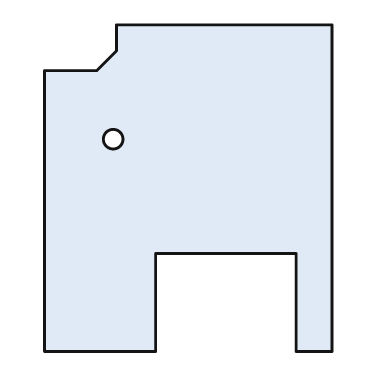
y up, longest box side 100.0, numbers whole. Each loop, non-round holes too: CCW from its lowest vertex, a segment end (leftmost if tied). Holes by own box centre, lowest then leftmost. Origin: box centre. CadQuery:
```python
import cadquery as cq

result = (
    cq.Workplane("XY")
    .moveTo(-44.0, -50.0)
    .lineTo(-10.0, -50.0)
    .lineTo(-10.0, -20.0)
    .lineTo(33.0, -20.0)
    .lineTo(33.0, -50.0)
    .lineTo(44.0, -50.0)
    .lineTo(44.0, 50.0)
    .lineTo(-22.0, 50.0)
    .lineTo(-22.0, 42.0)
    .lineTo(-28.0, 36.0)
    .lineTo(-44.0, 36.0)
    .close()
    .moveTo(-23.0, 15.0)
    .circle(3.0)
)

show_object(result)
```